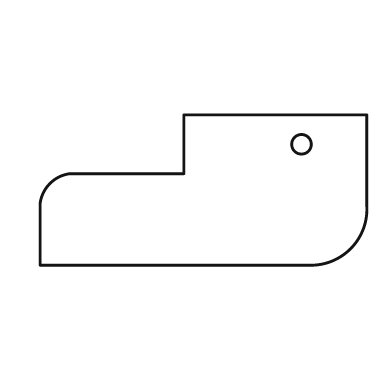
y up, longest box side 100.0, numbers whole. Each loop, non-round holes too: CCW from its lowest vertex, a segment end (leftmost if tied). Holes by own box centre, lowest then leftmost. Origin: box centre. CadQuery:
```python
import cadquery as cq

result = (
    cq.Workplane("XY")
    .moveTo(-50.0, -23.0)
    .lineTo(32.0, -23.0)
    .threePointArc((45.0, -18.0), (50.0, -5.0))
    .lineTo(50.0, 23.0)
    .lineTo(-6.0, 23.0)
    .lineTo(-6.0, 5.0)
    .lineTo(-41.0, 5.0)
    .threePointArc((-47.0, 2.0), (-50.0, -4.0))
    .close()
    .moveTo(30.0, 14.0)
    .circle(3.0)
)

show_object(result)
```